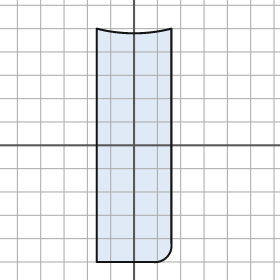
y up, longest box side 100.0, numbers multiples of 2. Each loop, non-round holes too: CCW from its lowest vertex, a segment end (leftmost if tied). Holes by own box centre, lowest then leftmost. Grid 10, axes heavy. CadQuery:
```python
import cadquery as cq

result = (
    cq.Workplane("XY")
    .moveTo(-16.0, -50.0)
    .lineTo(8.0, -50.0)
    .threePointArc((14.0, -48.0), (16.0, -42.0))
    .lineTo(16.0, 50.0)
    .threePointArc((0.0, 48.0), (-16.0, 50.0))
    .close()
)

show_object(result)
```